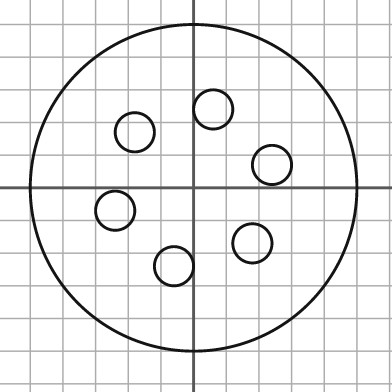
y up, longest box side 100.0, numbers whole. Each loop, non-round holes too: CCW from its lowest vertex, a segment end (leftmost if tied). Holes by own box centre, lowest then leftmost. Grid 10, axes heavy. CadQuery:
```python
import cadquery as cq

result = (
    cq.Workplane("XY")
    .moveTo(0.0, 0.0)
    .circle(50.0)
    .moveTo(-6.0, -24.0)
    .circle(6.0)
    .moveTo(18.0, -17.0)
    .circle(6.0)
    .moveTo(-24.0, -7.0)
    .circle(6.0)
    .moveTo(24.0, 7.0)
    .circle(6.0)
    .moveTo(-18.0, 17.0)
    .circle(6.0)
    .moveTo(6.0, 24.0)
    .circle(6.0)
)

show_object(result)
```